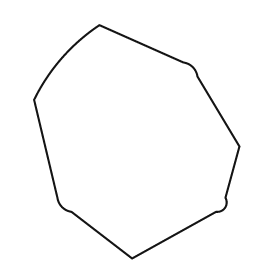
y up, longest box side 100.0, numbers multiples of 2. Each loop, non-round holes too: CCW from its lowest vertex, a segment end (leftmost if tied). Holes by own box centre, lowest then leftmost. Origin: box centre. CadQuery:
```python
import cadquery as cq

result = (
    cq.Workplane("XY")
    .moveTo(-2.0, -50.0)
    .lineTo(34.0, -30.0)
    .threePointArc((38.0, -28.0), (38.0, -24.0))
    .lineTo(44.0, -2.0)
    .lineTo(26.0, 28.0)
    .threePointArc((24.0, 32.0), (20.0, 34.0))
    .lineTo(-16.0, 50.0)
    .threePointArc((-32.0, 36.0), (-44.0, 18.0))
    .lineTo(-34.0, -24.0)
    .threePointArc((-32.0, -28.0), (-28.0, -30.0))
    .close()
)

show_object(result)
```